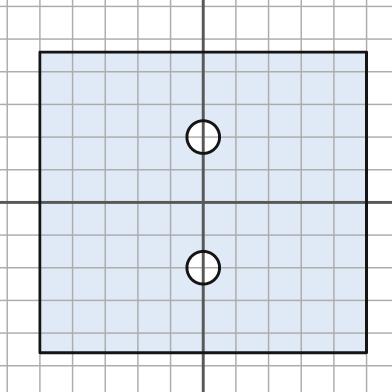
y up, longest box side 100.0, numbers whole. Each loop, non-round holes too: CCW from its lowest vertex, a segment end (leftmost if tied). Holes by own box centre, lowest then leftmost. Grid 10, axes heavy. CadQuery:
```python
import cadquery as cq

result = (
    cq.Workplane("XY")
    .moveTo(-50.0, -46.0)
    .lineTo(50.0, -46.0)
    .lineTo(50.0, 46.0)
    .lineTo(-50.0, 46.0)
    .close()
    .moveTo(0.0, -20.0)
    .circle(5.0)
    .moveTo(0.0, 20.0)
    .circle(5.0)
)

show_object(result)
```